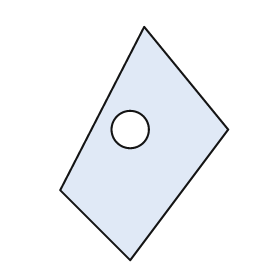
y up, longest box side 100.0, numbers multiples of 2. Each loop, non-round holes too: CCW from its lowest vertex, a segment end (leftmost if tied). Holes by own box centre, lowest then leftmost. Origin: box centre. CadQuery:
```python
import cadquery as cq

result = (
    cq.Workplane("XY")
    .moveTo(-6.0, -50.0)
    .lineTo(36.0, 6.0)
    .lineTo(0.0, 50.0)
    .lineTo(-36.0, -20.0)
    .close()
    .moveTo(-6.0, 6.0)
    .circle(8.0)
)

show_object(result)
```